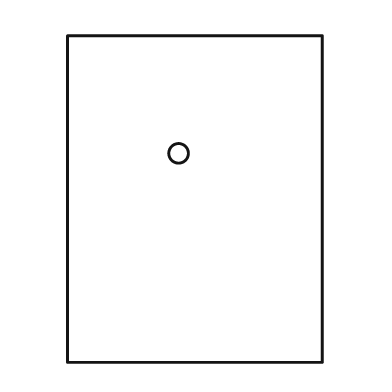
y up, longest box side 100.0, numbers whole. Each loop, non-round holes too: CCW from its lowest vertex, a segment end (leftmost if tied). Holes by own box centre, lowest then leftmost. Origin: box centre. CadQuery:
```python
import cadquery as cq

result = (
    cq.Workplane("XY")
    .moveTo(-39.0, -50.0)
    .lineTo(39.0, -50.0)
    .lineTo(39.0, 50.0)
    .lineTo(-39.0, 50.0)
    .close()
    .moveTo(-5.0, 14.0)
    .circle(3.0)
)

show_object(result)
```